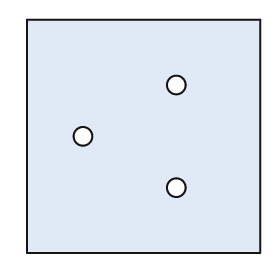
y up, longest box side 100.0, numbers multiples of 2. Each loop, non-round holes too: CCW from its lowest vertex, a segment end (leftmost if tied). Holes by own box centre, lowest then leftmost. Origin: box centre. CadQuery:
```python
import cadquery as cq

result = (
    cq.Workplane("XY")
    .moveTo(-50.0, -50.0)
    .lineTo(50.0, -50.0)
    .lineTo(50.0, 50.0)
    .lineTo(-50.0, 50.0)
    .close()
    .moveTo(14.0, -22.0)
    .circle(4.0)
    .moveTo(-26.0, 0.0)
    .circle(4.0)
    .moveTo(14.0, 22.0)
    .circle(4.0)
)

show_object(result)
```